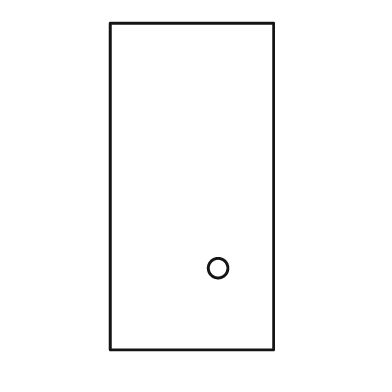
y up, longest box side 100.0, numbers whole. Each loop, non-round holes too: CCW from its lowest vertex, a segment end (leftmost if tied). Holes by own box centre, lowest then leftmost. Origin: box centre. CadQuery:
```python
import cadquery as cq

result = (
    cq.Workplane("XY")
    .moveTo(-25.0, -50.0)
    .lineTo(25.0, -50.0)
    .lineTo(25.0, 50.0)
    .lineTo(-25.0, 50.0)
    .close()
    .moveTo(8.0, -25.0)
    .circle(3.0)
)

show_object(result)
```